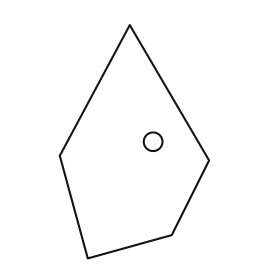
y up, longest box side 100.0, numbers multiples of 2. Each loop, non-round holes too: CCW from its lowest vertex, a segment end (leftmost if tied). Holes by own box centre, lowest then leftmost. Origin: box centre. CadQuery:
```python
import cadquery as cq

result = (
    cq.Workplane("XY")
    .moveTo(-20.0, -50.0)
    .lineTo(16.0, -40.0)
    .lineTo(32.0, -8.0)
    .lineTo(-2.0, 50.0)
    .lineTo(-32.0, -6.0)
    .close()
    .moveTo(8.0, 0.0)
    .circle(4.0)
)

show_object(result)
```